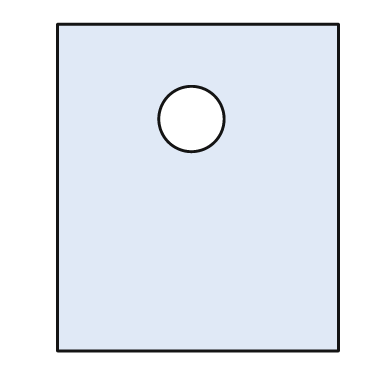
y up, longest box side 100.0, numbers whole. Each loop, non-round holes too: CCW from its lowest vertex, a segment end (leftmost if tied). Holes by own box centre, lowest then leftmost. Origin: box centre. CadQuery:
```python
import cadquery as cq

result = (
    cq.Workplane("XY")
    .moveTo(-43.0, -50.0)
    .lineTo(43.0, -50.0)
    .lineTo(43.0, 50.0)
    .lineTo(-43.0, 50.0)
    .close()
    .moveTo(-2.0, 21.0)
    .circle(10.0)
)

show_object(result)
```